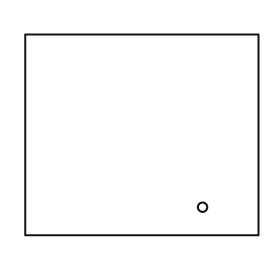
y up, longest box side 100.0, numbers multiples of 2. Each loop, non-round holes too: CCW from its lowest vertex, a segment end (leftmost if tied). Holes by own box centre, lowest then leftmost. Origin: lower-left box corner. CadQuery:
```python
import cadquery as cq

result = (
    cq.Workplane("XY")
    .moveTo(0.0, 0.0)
    .lineTo(100.0, 0.0)
    .lineTo(100.0, 86.0)
    .lineTo(0.0, 86.0)
    .close()
    .moveTo(76.0, 12.0)
    .circle(2.0)
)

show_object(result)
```